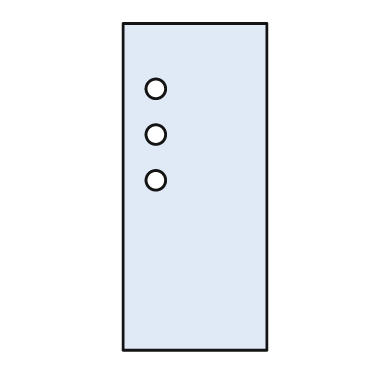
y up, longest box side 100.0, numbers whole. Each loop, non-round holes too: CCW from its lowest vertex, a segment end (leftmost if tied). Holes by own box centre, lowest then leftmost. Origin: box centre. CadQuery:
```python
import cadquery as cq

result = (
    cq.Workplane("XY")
    .moveTo(-22.0, -50.0)
    .lineTo(22.0, -50.0)
    .lineTo(22.0, 50.0)
    .lineTo(-22.0, 50.0)
    .close()
    .moveTo(-12.0, 2.0)
    .circle(3.0)
    .moveTo(-12.0, 16.0)
    .circle(3.0)
    .moveTo(-12.0, 30.0)
    .circle(3.0)
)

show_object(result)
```